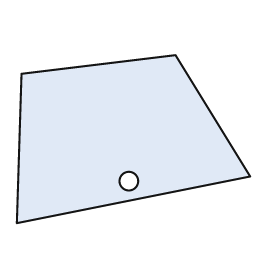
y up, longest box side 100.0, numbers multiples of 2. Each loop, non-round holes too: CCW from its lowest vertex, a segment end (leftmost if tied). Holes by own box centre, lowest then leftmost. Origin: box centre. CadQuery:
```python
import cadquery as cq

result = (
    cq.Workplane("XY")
    .moveTo(-50.0, -36.0)
    .lineTo(50.0, -16.0)
    .lineTo(18.0, 36.0)
    .lineTo(-48.0, 28.0)
    .close()
    .moveTo(-2.0, -18.0)
    .circle(4.0)
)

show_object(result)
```